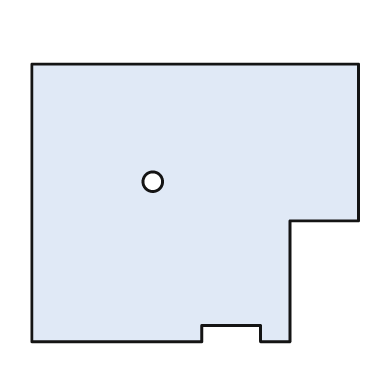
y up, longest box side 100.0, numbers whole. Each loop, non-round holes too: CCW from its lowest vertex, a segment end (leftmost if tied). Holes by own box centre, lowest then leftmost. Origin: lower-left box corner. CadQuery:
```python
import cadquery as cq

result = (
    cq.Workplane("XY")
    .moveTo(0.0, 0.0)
    .lineTo(52.0, 0.0)
    .lineTo(52.0, 5.0)
    .lineTo(70.0, 5.0)
    .lineTo(70.0, 0.0)
    .lineTo(79.0, 0.0)
    .lineTo(79.0, 37.0)
    .lineTo(100.0, 37.0)
    .lineTo(100.0, 85.0)
    .lineTo(0.0, 85.0)
    .close()
    .moveTo(37.0, 49.0)
    .circle(3.0)
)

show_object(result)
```